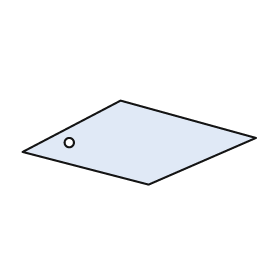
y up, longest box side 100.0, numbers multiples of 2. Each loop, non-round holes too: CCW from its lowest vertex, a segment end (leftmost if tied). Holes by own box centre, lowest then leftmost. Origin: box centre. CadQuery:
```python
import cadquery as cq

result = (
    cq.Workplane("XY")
    .moveTo(4.0, -18.0)
    .lineTo(50.0, 2.0)
    .lineTo(-8.0, 18.0)
    .lineTo(-50.0, -4.0)
    .close()
    .moveTo(-30.0, 0.0)
    .circle(2.0)
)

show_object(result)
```